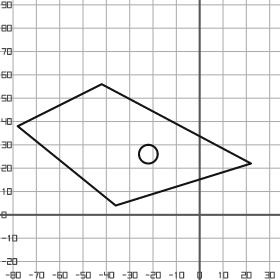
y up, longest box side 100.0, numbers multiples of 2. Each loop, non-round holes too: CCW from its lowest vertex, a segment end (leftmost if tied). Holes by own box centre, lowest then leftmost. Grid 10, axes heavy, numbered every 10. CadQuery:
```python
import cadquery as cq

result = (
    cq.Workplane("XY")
    .moveTo(-36.0, 4.0)
    .lineTo(22.0, 22.0)
    .lineTo(-42.0, 56.0)
    .lineTo(-78.0, 38.0)
    .close()
    .moveTo(-22.0, 26.0)
    .circle(4.0)
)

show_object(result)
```